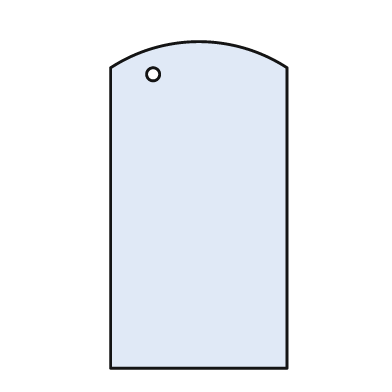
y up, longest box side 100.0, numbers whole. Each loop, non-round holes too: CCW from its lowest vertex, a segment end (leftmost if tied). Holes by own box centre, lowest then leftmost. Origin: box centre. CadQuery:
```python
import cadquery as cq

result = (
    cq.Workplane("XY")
    .moveTo(-27.0, -50.0)
    .lineTo(27.0, -50.0)
    .lineTo(27.0, 42.0)
    .threePointArc((0.0, 50.0), (-27.0, 42.0))
    .close()
    .moveTo(-14.0, 40.0)
    .circle(2.0)
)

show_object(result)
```